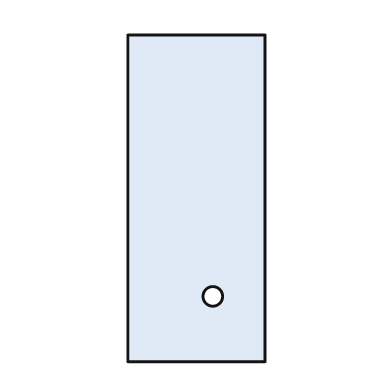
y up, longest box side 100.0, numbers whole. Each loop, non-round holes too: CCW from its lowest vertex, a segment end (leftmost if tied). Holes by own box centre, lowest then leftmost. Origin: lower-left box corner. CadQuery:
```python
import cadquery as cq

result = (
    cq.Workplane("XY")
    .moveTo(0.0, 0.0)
    .lineTo(42.0, 0.0)
    .lineTo(42.0, 100.0)
    .lineTo(0.0, 100.0)
    .close()
    .moveTo(26.0, 20.0)
    .circle(3.0)
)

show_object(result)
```